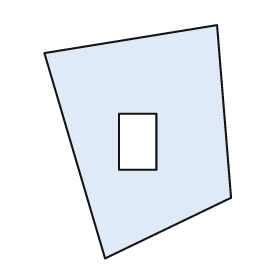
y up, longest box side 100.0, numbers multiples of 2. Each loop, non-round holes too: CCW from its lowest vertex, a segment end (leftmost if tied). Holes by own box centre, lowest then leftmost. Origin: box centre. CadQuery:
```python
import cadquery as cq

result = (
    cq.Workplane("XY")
    .moveTo(-14.0, -50.0)
    .lineTo(40.0, -24.0)
    .lineTo(34.0, 50.0)
    .lineTo(-40.0, 38.0)
    .close()
    .moveTo(-8.0, -12.0)
    .lineTo(8.0, -12.0)
    .lineTo(8.0, 12.0)
    .lineTo(-8.0, 12.0)
    .close()
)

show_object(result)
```